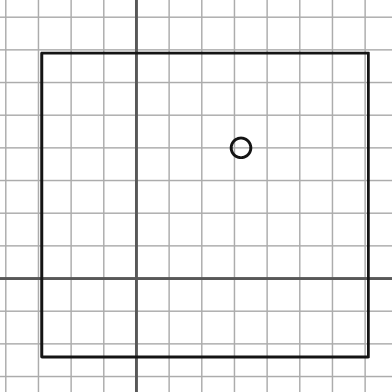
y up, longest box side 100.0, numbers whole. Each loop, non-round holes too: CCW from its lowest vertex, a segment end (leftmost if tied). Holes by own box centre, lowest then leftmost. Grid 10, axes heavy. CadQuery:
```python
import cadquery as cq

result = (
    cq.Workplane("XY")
    .moveTo(-29.0, -24.0)
    .lineTo(71.0, -24.0)
    .lineTo(71.0, 69.0)
    .lineTo(-29.0, 69.0)
    .close()
    .moveTo(32.0, 40.0)
    .circle(3.0)
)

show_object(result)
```